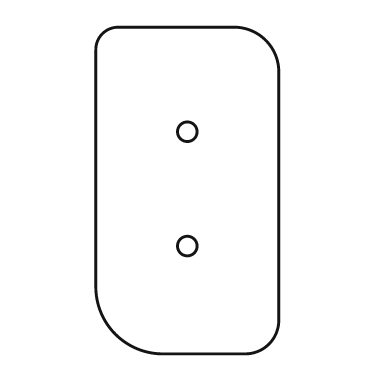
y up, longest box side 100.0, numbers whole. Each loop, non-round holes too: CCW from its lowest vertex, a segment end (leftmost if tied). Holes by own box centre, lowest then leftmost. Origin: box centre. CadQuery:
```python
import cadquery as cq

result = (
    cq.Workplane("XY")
    .moveTo(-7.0, -50.0)
    .lineTo(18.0, -50.0)
    .threePointArc((25.0, -47.0), (28.0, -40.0))
    .lineTo(28.0, 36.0)
    .threePointArc((24.0, 46.0), (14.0, 50.0))
    .lineTo(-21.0, 50.0)
    .threePointArc((-26.0, 48.0), (-28.0, 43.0))
    .lineTo(-28.0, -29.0)
    .threePointArc((-22.0, -44.0), (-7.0, -50.0))
    .close()
    .moveTo(0.0, -17.0)
    .circle(3.0)
    .moveTo(0.0, 18.0)
    .circle(3.0)
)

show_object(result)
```